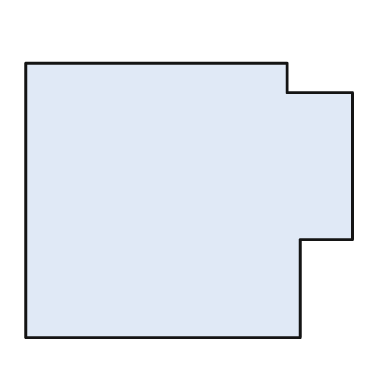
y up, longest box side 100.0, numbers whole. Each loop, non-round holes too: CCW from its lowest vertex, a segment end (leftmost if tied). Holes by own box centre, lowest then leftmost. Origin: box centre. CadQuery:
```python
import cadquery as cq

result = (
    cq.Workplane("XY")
    .moveTo(-50.0, -42.0)
    .lineTo(34.0, -42.0)
    .lineTo(34.0, -12.0)
    .lineTo(50.0, -12.0)
    .lineTo(50.0, 33.0)
    .lineTo(30.0, 33.0)
    .lineTo(30.0, 42.0)
    .lineTo(-50.0, 42.0)
    .close()
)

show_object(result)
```